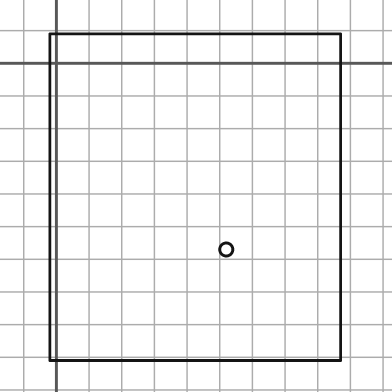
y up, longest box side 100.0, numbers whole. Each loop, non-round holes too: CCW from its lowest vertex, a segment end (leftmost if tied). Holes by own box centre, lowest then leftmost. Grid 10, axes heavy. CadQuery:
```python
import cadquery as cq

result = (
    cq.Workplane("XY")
    .moveTo(-2.0, -91.0)
    .lineTo(87.0, -91.0)
    .lineTo(87.0, 9.0)
    .lineTo(-2.0, 9.0)
    .close()
    .moveTo(52.0, -57.0)
    .circle(2.0)
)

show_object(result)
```